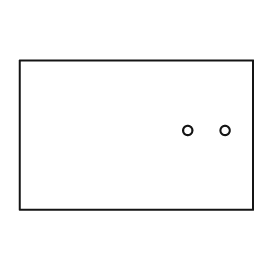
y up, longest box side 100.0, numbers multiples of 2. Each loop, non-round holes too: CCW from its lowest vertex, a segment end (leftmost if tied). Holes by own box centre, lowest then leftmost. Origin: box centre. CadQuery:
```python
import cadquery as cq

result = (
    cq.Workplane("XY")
    .moveTo(-50.0, -32.0)
    .lineTo(50.0, -32.0)
    .lineTo(50.0, 32.0)
    .lineTo(-50.0, 32.0)
    .close()
    .moveTo(22.0, 2.0)
    .circle(2.0)
    .moveTo(38.0, 2.0)
    .circle(2.0)
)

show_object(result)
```